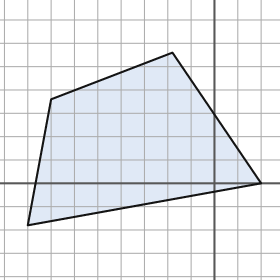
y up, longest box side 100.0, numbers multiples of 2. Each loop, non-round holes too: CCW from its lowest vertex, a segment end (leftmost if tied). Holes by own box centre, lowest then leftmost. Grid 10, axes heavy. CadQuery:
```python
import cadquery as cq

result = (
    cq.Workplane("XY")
    .moveTo(-80.0, -18.0)
    .lineTo(20.0, 0.0)
    .lineTo(-18.0, 56.0)
    .lineTo(-70.0, 36.0)
    .close()
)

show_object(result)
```